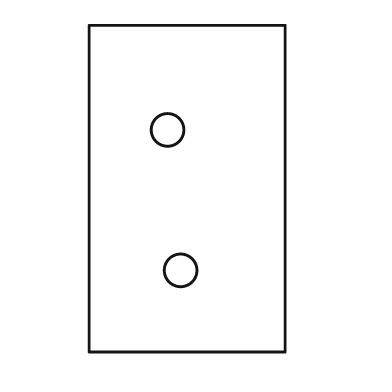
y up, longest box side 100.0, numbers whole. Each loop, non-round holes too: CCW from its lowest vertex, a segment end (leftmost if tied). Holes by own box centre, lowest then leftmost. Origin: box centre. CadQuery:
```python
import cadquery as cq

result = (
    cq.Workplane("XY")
    .moveTo(-30.0, -50.0)
    .lineTo(30.0, -50.0)
    .lineTo(30.0, 50.0)
    .lineTo(-30.0, 50.0)
    .close()
    .moveTo(-2.0, -25.0)
    .circle(5.0)
    .moveTo(-6.0, 18.0)
    .circle(5.0)
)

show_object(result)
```